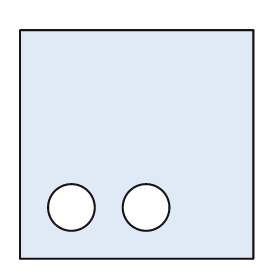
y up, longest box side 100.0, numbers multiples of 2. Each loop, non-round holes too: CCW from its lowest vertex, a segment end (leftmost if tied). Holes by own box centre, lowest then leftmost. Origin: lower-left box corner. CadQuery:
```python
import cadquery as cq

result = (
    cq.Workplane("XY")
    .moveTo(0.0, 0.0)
    .lineTo(100.0, 0.0)
    .lineTo(100.0, 98.0)
    .lineTo(0.0, 98.0)
    .close()
    .moveTo(22.0, 22.0)
    .circle(10.0)
    .moveTo(54.0, 22.0)
    .circle(10.0)
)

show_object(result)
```